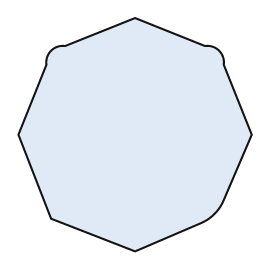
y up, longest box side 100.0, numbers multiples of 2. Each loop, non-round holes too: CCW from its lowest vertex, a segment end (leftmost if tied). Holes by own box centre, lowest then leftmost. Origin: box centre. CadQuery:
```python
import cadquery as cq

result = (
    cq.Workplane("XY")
    .moveTo(0.0, -50.0)
    .lineTo(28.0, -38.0)
    .threePointArc((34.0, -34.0), (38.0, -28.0))
    .lineTo(50.0, 0.0)
    .lineTo(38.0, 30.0)
    .threePointArc((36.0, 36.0), (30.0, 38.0))
    .lineTo(0.0, 50.0)
    .lineTo(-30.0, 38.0)
    .threePointArc((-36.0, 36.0), (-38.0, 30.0))
    .lineTo(-50.0, 0.0)
    .lineTo(-36.0, -36.0)
    .close()
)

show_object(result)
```